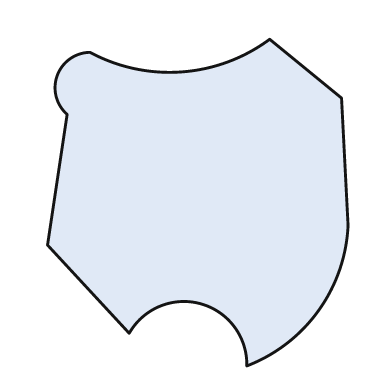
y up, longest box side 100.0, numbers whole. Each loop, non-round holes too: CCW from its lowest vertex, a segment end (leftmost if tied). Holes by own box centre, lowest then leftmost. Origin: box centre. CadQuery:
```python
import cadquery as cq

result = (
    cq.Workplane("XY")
    .moveTo(15.0, -50.0)
    .threePointArc((37.0, -33.0), (46.0, -7.0))
    .lineTo(44.0, 32.0)
    .lineTo(22.0, 50.0)
    .threePointArc((-5.0, 40.0), (-33.0, 46.0))
    .threePointArc((-43.0, 39.0), (-40.0, 27.0))
    .lineTo(-46.0, -13.0)
    .lineTo(-21.0, -40.0)
    .threePointArc((1.0, -31.0), (15.0, -50.0))
    .close()
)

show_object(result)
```